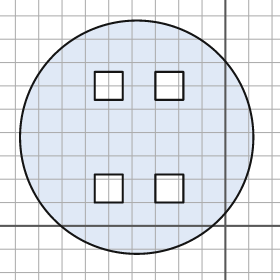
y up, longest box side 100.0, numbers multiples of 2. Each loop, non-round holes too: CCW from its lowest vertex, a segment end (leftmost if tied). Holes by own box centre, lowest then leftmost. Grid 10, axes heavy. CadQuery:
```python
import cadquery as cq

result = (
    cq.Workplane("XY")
    .moveTo(-38.0, 38.0)
    .circle(50.0)
    .moveTo(-56.0, 10.0)
    .lineTo(-44.0, 10.0)
    .lineTo(-44.0, 22.0)
    .lineTo(-56.0, 22.0)
    .close()
    .moveTo(-30.0, 10.0)
    .lineTo(-18.0, 10.0)
    .lineTo(-18.0, 22.0)
    .lineTo(-30.0, 22.0)
    .close()
    .moveTo(-56.0, 54.0)
    .lineTo(-44.0, 54.0)
    .lineTo(-44.0, 66.0)
    .lineTo(-56.0, 66.0)
    .close()
    .moveTo(-30.0, 54.0)
    .lineTo(-18.0, 54.0)
    .lineTo(-18.0, 66.0)
    .lineTo(-30.0, 66.0)
    .close()
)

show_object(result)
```